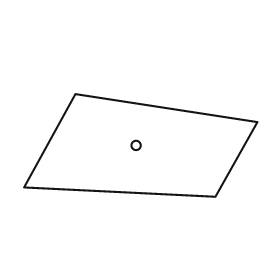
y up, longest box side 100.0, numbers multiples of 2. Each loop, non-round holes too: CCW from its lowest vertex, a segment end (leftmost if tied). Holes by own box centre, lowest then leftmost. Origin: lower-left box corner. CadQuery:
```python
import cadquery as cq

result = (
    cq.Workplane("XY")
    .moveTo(82.0, 0.0)
    .lineTo(100.0, 32.0)
    .lineTo(22.0, 44.0)
    .lineTo(0.0, 4.0)
    .close()
    .moveTo(48.0, 22.0)
    .circle(2.0)
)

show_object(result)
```